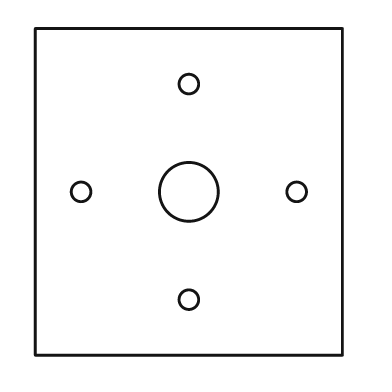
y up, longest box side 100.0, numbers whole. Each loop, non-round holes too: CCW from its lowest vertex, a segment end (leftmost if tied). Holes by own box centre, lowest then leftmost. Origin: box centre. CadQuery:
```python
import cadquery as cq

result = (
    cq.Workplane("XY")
    .moveTo(-47.0, -50.0)
    .lineTo(47.0, -50.0)
    .lineTo(47.0, 50.0)
    .lineTo(-47.0, 50.0)
    .close()
    .moveTo(0.0, -33.0)
    .circle(3.0)
    .moveTo(-33.0, 0.0)
    .circle(3.0)
    .moveTo(0.0, 0.0)
    .circle(9.0)
    .moveTo(33.0, 0.0)
    .circle(3.0)
    .moveTo(0.0, 33.0)
    .circle(3.0)
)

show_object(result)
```